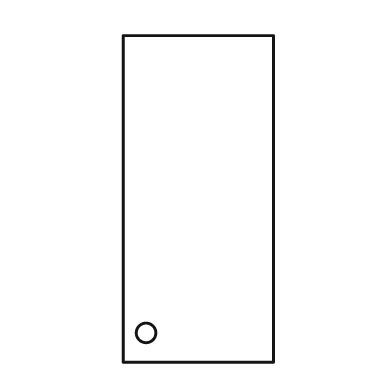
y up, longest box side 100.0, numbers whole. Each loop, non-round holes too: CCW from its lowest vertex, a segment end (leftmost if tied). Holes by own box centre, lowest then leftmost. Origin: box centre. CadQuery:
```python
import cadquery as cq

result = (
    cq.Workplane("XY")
    .moveTo(-23.0, -50.0)
    .lineTo(23.0, -50.0)
    .lineTo(23.0, 50.0)
    .lineTo(-23.0, 50.0)
    .close()
    .moveTo(-16.0, -41.0)
    .circle(3.0)
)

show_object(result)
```